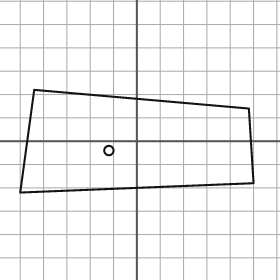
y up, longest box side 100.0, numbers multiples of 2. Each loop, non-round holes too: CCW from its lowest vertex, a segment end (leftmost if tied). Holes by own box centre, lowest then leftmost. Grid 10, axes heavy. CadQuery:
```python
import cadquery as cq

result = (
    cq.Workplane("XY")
    .moveTo(-50.0, -22.0)
    .lineTo(50.0, -18.0)
    .lineTo(48.0, 14.0)
    .lineTo(-44.0, 22.0)
    .close()
    .moveTo(-12.0, -4.0)
    .circle(2.0)
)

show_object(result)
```